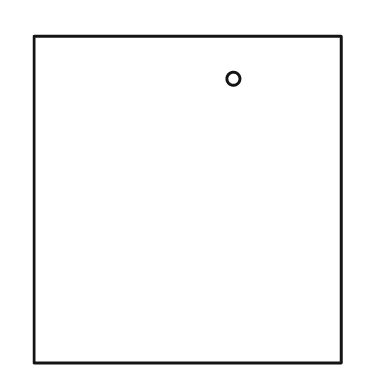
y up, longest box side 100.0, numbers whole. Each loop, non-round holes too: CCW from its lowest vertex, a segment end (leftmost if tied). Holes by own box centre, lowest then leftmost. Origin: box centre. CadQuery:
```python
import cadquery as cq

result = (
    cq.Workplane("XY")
    .moveTo(-47.0, -50.0)
    .lineTo(47.0, -50.0)
    .lineTo(47.0, 50.0)
    .lineTo(-47.0, 50.0)
    .close()
    .moveTo(14.0, 37.0)
    .circle(2.0)
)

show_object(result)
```